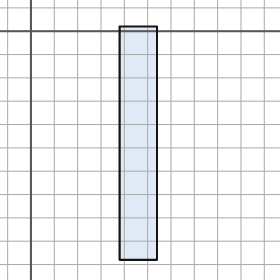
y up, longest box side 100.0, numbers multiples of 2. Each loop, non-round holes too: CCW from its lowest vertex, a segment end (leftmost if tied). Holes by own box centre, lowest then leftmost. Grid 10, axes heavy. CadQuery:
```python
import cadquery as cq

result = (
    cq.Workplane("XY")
    .moveTo(38.0, -98.0)
    .lineTo(54.0, -98.0)
    .lineTo(54.0, 2.0)
    .lineTo(38.0, 2.0)
    .close()
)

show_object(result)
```